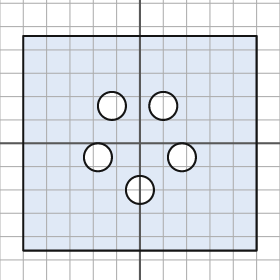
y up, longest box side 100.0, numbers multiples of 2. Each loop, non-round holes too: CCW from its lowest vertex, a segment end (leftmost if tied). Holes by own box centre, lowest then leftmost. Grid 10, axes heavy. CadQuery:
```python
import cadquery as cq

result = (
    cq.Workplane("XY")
    .moveTo(-50.0, -46.0)
    .lineTo(50.0, -46.0)
    .lineTo(50.0, 46.0)
    .lineTo(-50.0, 46.0)
    .close()
    .moveTo(0.0, -20.0)
    .circle(6.0)
    .moveTo(-18.0, -6.0)
    .circle(6.0)
    .moveTo(18.0, -6.0)
    .circle(6.0)
    .moveTo(-12.0, 16.0)
    .circle(6.0)
    .moveTo(10.0, 16.0)
    .circle(6.0)
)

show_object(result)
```